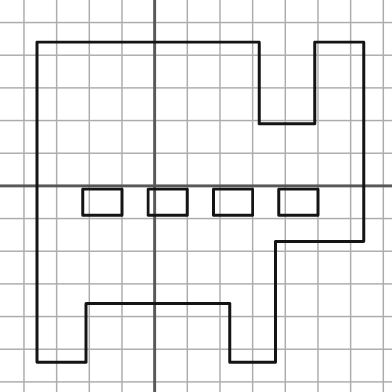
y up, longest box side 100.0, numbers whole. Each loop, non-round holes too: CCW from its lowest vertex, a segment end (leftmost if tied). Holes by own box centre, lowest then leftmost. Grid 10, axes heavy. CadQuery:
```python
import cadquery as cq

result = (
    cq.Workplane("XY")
    .moveTo(-36.0, -54.0)
    .lineTo(-21.0, -54.0)
    .lineTo(-21.0, -36.0)
    .lineTo(23.0, -36.0)
    .lineTo(23.0, -54.0)
    .lineTo(37.0, -54.0)
    .lineTo(37.0, -17.0)
    .lineTo(64.0, -17.0)
    .lineTo(64.0, 44.0)
    .lineTo(49.0, 44.0)
    .lineTo(49.0, 19.0)
    .lineTo(32.0, 19.0)
    .lineTo(32.0, 44.0)
    .lineTo(-36.0, 44.0)
    .close()
    .moveTo(-22.0, -9.0)
    .lineTo(-10.0, -9.0)
    .lineTo(-10.0, -1.0)
    .lineTo(-22.0, -1.0)
    .close()
    .moveTo(-2.0, -9.0)
    .lineTo(10.0, -9.0)
    .lineTo(10.0, -1.0)
    .lineTo(-2.0, -1.0)
    .close()
    .moveTo(18.0, -9.0)
    .lineTo(30.0, -9.0)
    .lineTo(30.0, -1.0)
    .lineTo(18.0, -1.0)
    .close()
    .moveTo(38.0, -9.0)
    .lineTo(50.0, -9.0)
    .lineTo(50.0, -1.0)
    .lineTo(38.0, -1.0)
    .close()
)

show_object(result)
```